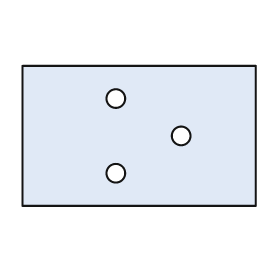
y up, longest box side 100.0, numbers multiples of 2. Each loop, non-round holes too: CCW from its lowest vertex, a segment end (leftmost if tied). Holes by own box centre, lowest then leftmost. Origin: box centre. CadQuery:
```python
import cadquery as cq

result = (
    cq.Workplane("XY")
    .moveTo(-50.0, -30.0)
    .lineTo(50.0, -30.0)
    .lineTo(50.0, 30.0)
    .lineTo(-50.0, 30.0)
    .close()
    .moveTo(-10.0, -16.0)
    .circle(4.0)
    .moveTo(18.0, 0.0)
    .circle(4.0)
    .moveTo(-10.0, 16.0)
    .circle(4.0)
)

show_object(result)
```